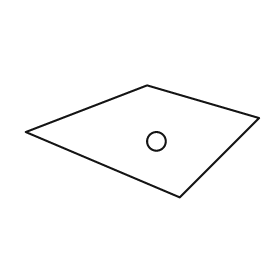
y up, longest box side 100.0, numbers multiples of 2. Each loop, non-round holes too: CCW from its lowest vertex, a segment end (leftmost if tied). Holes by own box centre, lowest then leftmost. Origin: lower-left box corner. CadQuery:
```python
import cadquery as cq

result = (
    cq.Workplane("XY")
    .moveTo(66.0, 0.0)
    .lineTo(100.0, 34.0)
    .lineTo(52.0, 48.0)
    .lineTo(0.0, 28.0)
    .close()
    .moveTo(56.0, 24.0)
    .circle(4.0)
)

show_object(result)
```